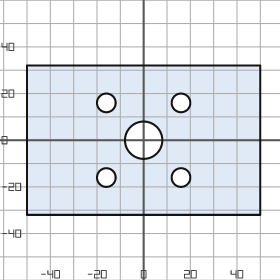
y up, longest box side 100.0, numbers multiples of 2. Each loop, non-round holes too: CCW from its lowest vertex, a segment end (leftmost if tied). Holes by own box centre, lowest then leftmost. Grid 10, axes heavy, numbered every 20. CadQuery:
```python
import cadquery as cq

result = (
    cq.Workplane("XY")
    .moveTo(-50.0, -32.0)
    .lineTo(50.0, -32.0)
    .lineTo(50.0, 32.0)
    .lineTo(-50.0, 32.0)
    .close()
    .moveTo(-16.0, -16.0)
    .circle(4.0)
    .moveTo(16.0, -16.0)
    .circle(4.0)
    .moveTo(0.0, 0.0)
    .circle(8.0)
    .moveTo(-16.0, 16.0)
    .circle(4.0)
    .moveTo(16.0, 16.0)
    .circle(4.0)
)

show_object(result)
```